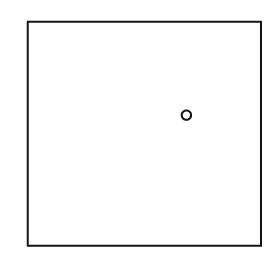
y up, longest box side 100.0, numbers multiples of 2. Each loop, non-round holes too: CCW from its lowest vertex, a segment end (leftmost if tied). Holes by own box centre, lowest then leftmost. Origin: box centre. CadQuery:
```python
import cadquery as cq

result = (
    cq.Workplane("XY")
    .moveTo(-50.0, -48.0)
    .lineTo(50.0, -48.0)
    .lineTo(50.0, 48.0)
    .lineTo(-50.0, 48.0)
    .close()
    .moveTo(18.0, 8.0)
    .circle(2.0)
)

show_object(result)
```